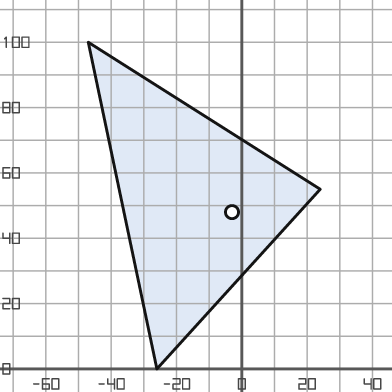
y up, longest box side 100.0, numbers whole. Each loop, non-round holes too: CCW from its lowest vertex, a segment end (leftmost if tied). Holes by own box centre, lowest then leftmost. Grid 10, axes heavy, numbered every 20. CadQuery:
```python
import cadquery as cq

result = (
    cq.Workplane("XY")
    .moveTo(-26.0, 0.0)
    .lineTo(24.0, 55.0)
    .lineTo(-47.0, 100.0)
    .close()
    .moveTo(-3.0, 48.0)
    .circle(2.0)
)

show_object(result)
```